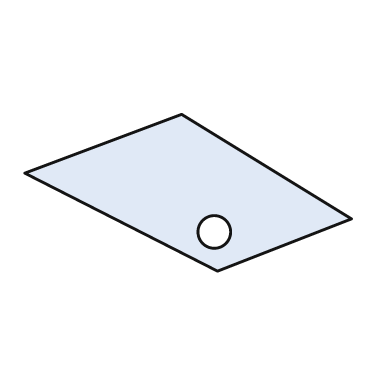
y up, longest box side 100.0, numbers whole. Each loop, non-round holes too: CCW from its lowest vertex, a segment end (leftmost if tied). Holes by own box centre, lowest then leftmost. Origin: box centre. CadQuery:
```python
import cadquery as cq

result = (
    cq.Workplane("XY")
    .moveTo(9.0, -24.0)
    .lineTo(50.0, -8.0)
    .lineTo(-2.0, 24.0)
    .lineTo(-50.0, 6.0)
    .close()
    .moveTo(8.0, -12.0)
    .circle(5.0)
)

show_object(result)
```